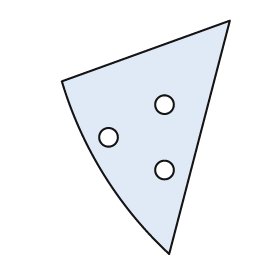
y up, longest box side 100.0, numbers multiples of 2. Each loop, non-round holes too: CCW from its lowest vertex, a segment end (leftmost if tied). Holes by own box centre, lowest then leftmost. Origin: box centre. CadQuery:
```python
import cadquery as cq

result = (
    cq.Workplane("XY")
    .moveTo(10.0, -50.0)
    .lineTo(36.0, 50.0)
    .lineTo(-36.0, 24.0)
    .threePointArc((-18.0, -16.0), (10.0, -50.0))
    .close()
    .moveTo(8.0, -14.0)
    .circle(4.0)
    .moveTo(-16.0, 0.0)
    .circle(4.0)
    .moveTo(8.0, 14.0)
    .circle(4.0)
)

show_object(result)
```